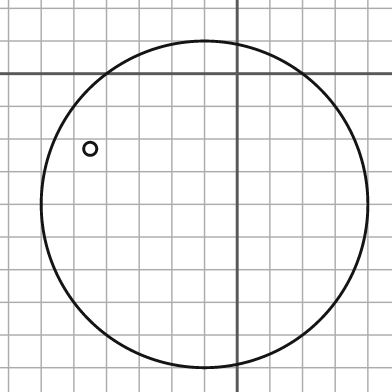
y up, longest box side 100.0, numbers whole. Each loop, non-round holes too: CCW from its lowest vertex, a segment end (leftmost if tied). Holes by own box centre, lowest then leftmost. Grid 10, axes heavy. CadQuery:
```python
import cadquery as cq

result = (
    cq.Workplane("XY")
    .moveTo(-10.0, -40.0)
    .circle(50.0)
    .moveTo(-45.0, -23.0)
    .circle(2.0)
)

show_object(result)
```